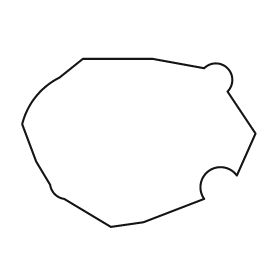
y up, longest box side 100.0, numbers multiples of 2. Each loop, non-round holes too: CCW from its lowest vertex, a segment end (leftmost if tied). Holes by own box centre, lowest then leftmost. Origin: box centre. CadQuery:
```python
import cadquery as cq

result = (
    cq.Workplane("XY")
    .moveTo(-12.0, -36.0)
    .lineTo(2.0, -34.0)
    .lineTo(28.0, -24.0)
    .threePointArc((30.0, -12.0), (42.0, -14.0))
    .lineTo(50.0, 4.0)
    .lineTo(38.0, 22.0)
    .threePointArc((38.0, 32.0), (28.0, 32.0))
    .lineTo(6.0, 36.0)
    .lineTo(-24.0, 36.0)
    .lineTo(-34.0, 28.0)
    .threePointArc((-44.0, 20.0), (-50.0, 8.0))
    .lineTo(-44.0, -8.0)
    .lineTo(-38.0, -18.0)
    .threePointArc((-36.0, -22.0), (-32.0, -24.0))
    .close()
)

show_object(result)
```